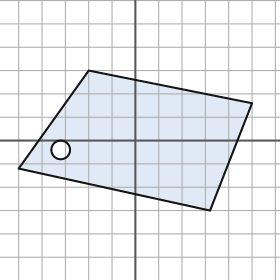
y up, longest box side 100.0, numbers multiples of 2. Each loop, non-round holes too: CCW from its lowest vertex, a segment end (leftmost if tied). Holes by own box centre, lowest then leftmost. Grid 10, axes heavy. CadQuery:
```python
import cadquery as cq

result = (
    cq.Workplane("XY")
    .moveTo(32.0, -30.0)
    .lineTo(50.0, 16.0)
    .lineTo(-20.0, 30.0)
    .lineTo(-50.0, -12.0)
    .close()
    .moveTo(-32.0, -4.0)
    .circle(4.0)
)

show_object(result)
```